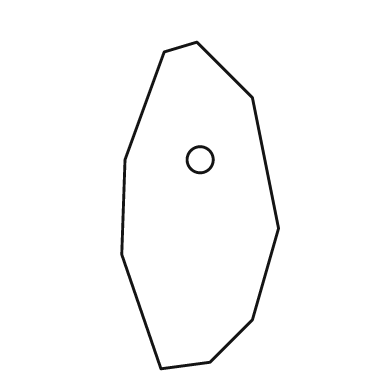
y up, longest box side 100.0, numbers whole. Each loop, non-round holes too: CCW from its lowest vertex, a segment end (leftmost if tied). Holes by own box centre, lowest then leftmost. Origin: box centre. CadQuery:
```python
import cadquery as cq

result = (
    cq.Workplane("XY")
    .moveTo(-12.0, -50.0)
    .lineTo(3.0, -48.0)
    .lineTo(16.0, -35.0)
    .lineTo(24.0, -7.0)
    .lineTo(16.0, 33.0)
    .lineTo(-1.0, 50.0)
    .lineTo(-11.0, 47.0)
    .lineTo(-23.0, 14.0)
    .lineTo(-24.0, -15.0)
    .close()
    .moveTo(0.0, 14.0)
    .circle(4.0)
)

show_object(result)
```